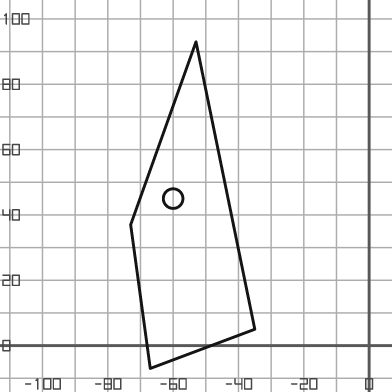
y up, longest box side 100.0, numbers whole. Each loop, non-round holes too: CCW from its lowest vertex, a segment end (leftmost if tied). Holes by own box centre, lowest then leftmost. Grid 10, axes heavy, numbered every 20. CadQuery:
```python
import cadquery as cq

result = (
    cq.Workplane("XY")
    .moveTo(-67.0, -7.0)
    .lineTo(-35.0, 5.0)
    .lineTo(-53.0, 93.0)
    .lineTo(-73.0, 37.0)
    .close()
    .moveTo(-60.0, 45.0)
    .circle(3.0)
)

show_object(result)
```